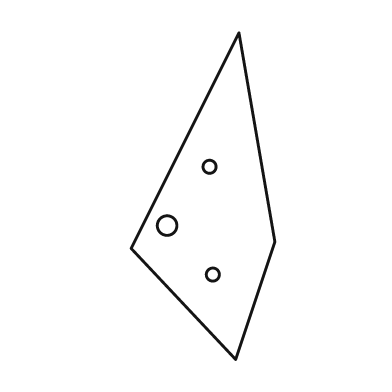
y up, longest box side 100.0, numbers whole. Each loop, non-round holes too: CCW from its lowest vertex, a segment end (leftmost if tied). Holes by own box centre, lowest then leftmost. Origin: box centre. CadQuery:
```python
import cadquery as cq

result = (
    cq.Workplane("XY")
    .moveTo(10.0, -50.0)
    .lineTo(22.0, -14.0)
    .lineTo(11.0, 50.0)
    .lineTo(-22.0, -16.0)
    .close()
    .moveTo(3.0, -24.0)
    .circle(2.0)
    .moveTo(-11.0, -9.0)
    .circle(3.0)
    .moveTo(2.0, 9.0)
    .circle(2.0)
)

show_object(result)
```